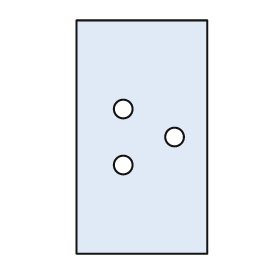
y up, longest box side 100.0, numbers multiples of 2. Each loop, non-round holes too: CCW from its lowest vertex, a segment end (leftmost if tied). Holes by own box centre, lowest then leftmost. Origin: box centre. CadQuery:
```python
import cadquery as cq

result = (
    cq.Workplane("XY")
    .moveTo(-28.0, -50.0)
    .lineTo(28.0, -50.0)
    .lineTo(28.0, 50.0)
    .lineTo(-28.0, 50.0)
    .close()
    .moveTo(-8.0, -12.0)
    .circle(4.0)
    .moveTo(14.0, 0.0)
    .circle(4.0)
    .moveTo(-8.0, 12.0)
    .circle(4.0)
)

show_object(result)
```